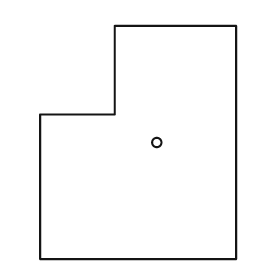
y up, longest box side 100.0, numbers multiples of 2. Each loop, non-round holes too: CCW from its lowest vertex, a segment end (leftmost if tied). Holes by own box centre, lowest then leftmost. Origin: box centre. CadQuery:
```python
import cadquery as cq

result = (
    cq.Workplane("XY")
    .moveTo(-42.0, -50.0)
    .lineTo(42.0, -50.0)
    .lineTo(42.0, 50.0)
    .lineTo(-10.0, 50.0)
    .lineTo(-10.0, 12.0)
    .lineTo(-42.0, 12.0)
    .close()
    .moveTo(8.0, 0.0)
    .circle(2.0)
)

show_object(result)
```